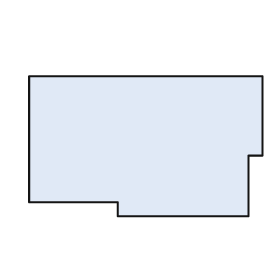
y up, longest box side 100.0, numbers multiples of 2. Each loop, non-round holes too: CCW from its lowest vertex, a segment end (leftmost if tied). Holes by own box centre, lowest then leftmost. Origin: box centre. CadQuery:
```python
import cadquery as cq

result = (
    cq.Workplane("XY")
    .moveTo(-12.0, -30.0)
    .lineTo(44.0, -30.0)
    .lineTo(44.0, -4.0)
    .lineTo(50.0, -4.0)
    .lineTo(50.0, 30.0)
    .lineTo(-50.0, 30.0)
    .lineTo(-50.0, -24.0)
    .lineTo(-12.0, -24.0)
    .close()
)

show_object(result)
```